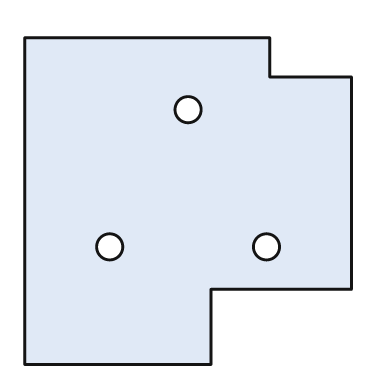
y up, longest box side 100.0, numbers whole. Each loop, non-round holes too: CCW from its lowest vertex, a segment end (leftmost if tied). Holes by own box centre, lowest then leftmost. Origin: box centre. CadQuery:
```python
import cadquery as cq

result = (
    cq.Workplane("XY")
    .moveTo(-50.0, -50.0)
    .lineTo(7.0, -50.0)
    .lineTo(7.0, -27.0)
    .lineTo(50.0, -27.0)
    .lineTo(50.0, 38.0)
    .lineTo(25.0, 38.0)
    .lineTo(25.0, 50.0)
    .lineTo(-50.0, 50.0)
    .close()
    .moveTo(-24.0, -14.0)
    .circle(4.0)
    .moveTo(24.0, -14.0)
    .circle(4.0)
    .moveTo(0.0, 28.0)
    .circle(4.0)
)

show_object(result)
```